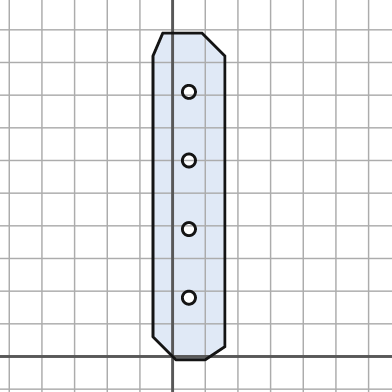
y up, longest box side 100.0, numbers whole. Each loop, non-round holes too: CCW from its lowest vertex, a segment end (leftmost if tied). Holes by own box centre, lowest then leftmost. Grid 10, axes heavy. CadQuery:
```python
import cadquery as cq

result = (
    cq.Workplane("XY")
    .moveTo(1.0, -1.0)
    .lineTo(10.0, -1.0)
    .lineTo(16.0, 3.0)
    .lineTo(16.0, 92.0)
    .lineTo(9.0, 99.0)
    .lineTo(-3.0, 99.0)
    .lineTo(-6.0, 92.0)
    .lineTo(-6.0, 6.0)
    .close()
    .moveTo(5.0, 18.0)
    .circle(2.0)
    .moveTo(5.0, 39.0)
    .circle(2.0)
    .moveTo(5.0, 60.0)
    .circle(2.0)
    .moveTo(5.0, 81.0)
    .circle(2.0)
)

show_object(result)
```